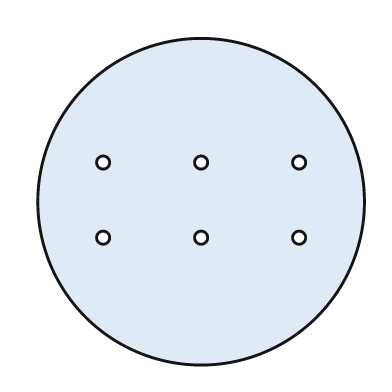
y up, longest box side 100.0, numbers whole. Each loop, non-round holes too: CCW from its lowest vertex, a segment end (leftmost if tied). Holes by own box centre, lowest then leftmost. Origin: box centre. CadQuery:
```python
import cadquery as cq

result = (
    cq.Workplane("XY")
    .moveTo(0.0, 0.0)
    .circle(50.0)
    .moveTo(-30.0, -11.0)
    .circle(2.0)
    .moveTo(0.0, -11.0)
    .circle(2.0)
    .moveTo(30.0, -11.0)
    .circle(2.0)
    .moveTo(-30.0, 12.0)
    .circle(2.0)
    .moveTo(0.0, 12.0)
    .circle(2.0)
    .moveTo(30.0, 12.0)
    .circle(2.0)
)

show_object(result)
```